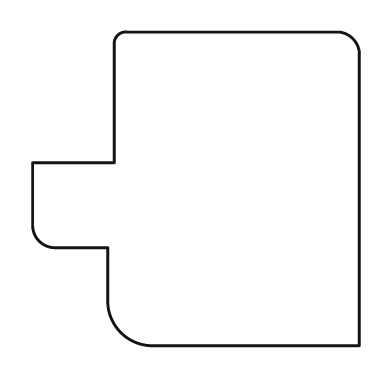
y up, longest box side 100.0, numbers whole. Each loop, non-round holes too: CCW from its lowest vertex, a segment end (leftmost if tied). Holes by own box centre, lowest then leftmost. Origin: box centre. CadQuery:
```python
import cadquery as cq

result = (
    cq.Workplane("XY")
    .moveTo(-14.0, -48.0)
    .lineTo(50.0, -48.0)
    .lineTo(50.0, 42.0)
    .threePointArc((48.0, 46.0), (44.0, 48.0))
    .lineTo(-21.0, 48.0)
    .threePointArc((-24.0, 47.0), (-25.0, 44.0))
    .lineTo(-25.0, 8.0)
    .lineTo(-50.0, 8.0)
    .lineTo(-50.0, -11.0)
    .threePointArc((-48.0, -16.0), (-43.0, -18.0))
    .lineTo(-27.0, -18.0)
    .lineTo(-27.0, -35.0)
    .threePointArc((-23.0, -44.0), (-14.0, -48.0))
    .close()
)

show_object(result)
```